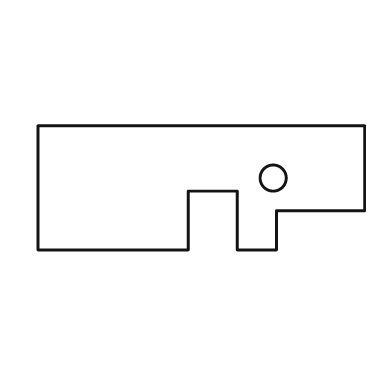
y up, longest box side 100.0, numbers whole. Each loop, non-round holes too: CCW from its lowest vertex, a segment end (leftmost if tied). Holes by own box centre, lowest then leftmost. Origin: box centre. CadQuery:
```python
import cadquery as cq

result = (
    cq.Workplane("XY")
    .moveTo(-50.0, -19.0)
    .lineTo(-4.0, -19.0)
    .lineTo(-4.0, -1.0)
    .lineTo(11.0, -1.0)
    .lineTo(11.0, -19.0)
    .lineTo(23.0, -19.0)
    .lineTo(23.0, -7.0)
    .lineTo(50.0, -7.0)
    .lineTo(50.0, 19.0)
    .lineTo(-50.0, 19.0)
    .close()
    .moveTo(22.0, 3.0)
    .circle(4.0)
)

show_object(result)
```